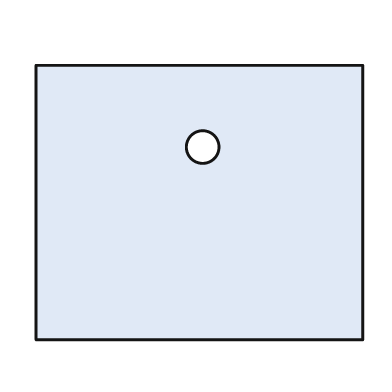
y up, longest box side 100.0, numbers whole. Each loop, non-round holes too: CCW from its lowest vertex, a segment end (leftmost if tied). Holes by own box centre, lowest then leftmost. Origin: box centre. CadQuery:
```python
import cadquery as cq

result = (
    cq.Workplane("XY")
    .moveTo(-50.0, -42.0)
    .lineTo(50.0, -42.0)
    .lineTo(50.0, 42.0)
    .lineTo(-50.0, 42.0)
    .close()
    .moveTo(1.0, 17.0)
    .circle(5.0)
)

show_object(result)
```